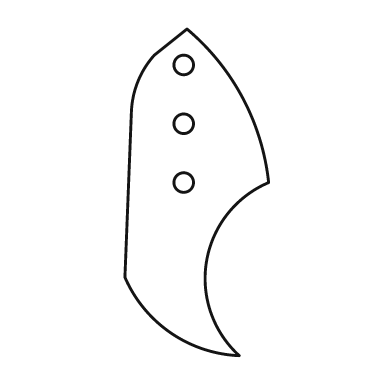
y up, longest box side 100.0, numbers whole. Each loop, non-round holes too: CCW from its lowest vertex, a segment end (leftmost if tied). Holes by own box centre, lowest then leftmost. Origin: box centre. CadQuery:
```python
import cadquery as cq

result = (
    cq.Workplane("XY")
    .moveTo(13.0, -50.0)
    .threePointArc((3.0, -21.0), (22.0, 3.0))
    .threePointArc((14.0, 29.0), (-3.0, 50.0))
    .lineTo(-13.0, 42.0)
    .threePointArc((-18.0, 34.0), (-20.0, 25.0))
    .lineTo(-22.0, -26.0)
    .threePointArc((-8.0, -43.0), (13.0, -50.0))
    .close()
    .moveTo(-4.0, 3.0)
    .circle(3.0)
    .moveTo(-4.0, 21.0)
    .circle(3.0)
    .moveTo(-4.0, 39.0)
    .circle(3.0)
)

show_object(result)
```